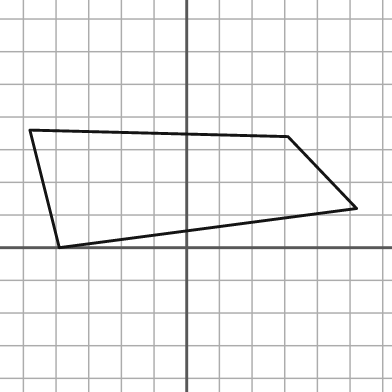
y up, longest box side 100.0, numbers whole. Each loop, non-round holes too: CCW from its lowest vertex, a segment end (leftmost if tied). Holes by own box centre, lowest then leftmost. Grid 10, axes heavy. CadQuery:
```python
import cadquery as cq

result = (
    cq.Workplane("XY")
    .moveTo(-39.0, 0.0)
    .lineTo(52.0, 12.0)
    .lineTo(31.0, 34.0)
    .lineTo(-48.0, 36.0)
    .close()
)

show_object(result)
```